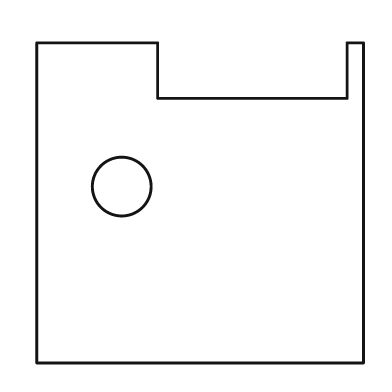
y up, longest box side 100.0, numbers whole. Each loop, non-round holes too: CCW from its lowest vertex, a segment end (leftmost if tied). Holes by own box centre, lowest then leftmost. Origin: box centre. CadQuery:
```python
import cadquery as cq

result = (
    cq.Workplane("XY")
    .moveTo(-50.0, -49.0)
    .lineTo(50.0, -49.0)
    .lineTo(50.0, 49.0)
    .lineTo(45.0, 49.0)
    .lineTo(45.0, 32.0)
    .lineTo(-13.0, 32.0)
    .lineTo(-13.0, 49.0)
    .lineTo(-50.0, 49.0)
    .close()
    .moveTo(-24.0, 5.0)
    .circle(9.0)
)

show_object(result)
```